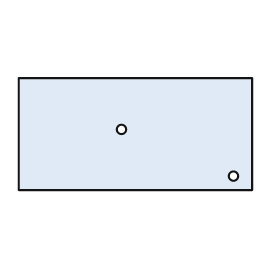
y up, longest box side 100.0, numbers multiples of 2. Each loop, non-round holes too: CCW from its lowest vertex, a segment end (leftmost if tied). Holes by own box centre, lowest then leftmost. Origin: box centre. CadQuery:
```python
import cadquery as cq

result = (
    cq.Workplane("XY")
    .moveTo(-50.0, -24.0)
    .lineTo(50.0, -24.0)
    .lineTo(50.0, 24.0)
    .lineTo(-50.0, 24.0)
    .close()
    .moveTo(42.0, -18.0)
    .circle(2.0)
    .moveTo(-6.0, 2.0)
    .circle(2.0)
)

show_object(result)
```